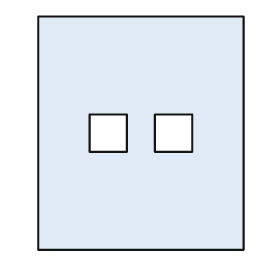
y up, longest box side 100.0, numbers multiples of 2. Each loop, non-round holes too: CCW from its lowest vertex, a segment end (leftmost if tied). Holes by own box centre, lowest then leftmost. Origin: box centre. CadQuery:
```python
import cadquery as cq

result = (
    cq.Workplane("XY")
    .moveTo(-44.0, -50.0)
    .lineTo(44.0, -50.0)
    .lineTo(44.0, 50.0)
    .lineTo(-44.0, 50.0)
    .close()
    .moveTo(-22.0, -8.0)
    .lineTo(-6.0, -8.0)
    .lineTo(-6.0, 8.0)
    .lineTo(-22.0, 8.0)
    .close()
    .moveTo(6.0, -8.0)
    .lineTo(22.0, -8.0)
    .lineTo(22.0, 8.0)
    .lineTo(6.0, 8.0)
    .close()
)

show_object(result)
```